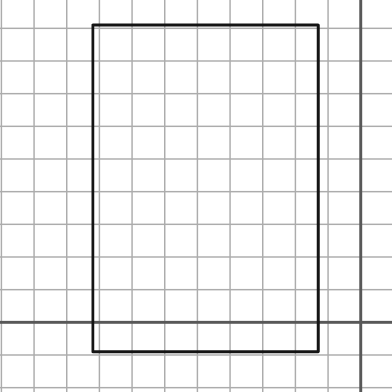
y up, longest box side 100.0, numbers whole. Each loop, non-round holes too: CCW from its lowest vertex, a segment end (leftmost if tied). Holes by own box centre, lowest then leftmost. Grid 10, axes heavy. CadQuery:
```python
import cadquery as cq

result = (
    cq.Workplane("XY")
    .moveTo(-82.0, -9.0)
    .lineTo(-13.0, -9.0)
    .lineTo(-13.0, 91.0)
    .lineTo(-82.0, 91.0)
    .close()
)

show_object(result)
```